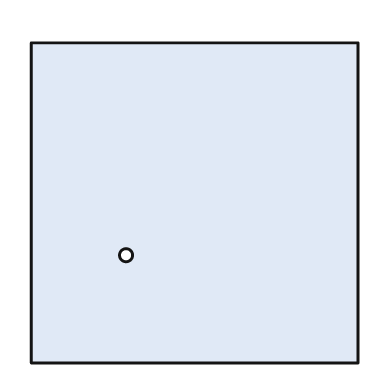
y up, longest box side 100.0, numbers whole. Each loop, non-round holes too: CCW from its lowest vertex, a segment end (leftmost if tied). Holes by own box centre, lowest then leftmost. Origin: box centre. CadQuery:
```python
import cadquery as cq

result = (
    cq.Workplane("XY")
    .moveTo(-50.0, -49.0)
    .lineTo(50.0, -49.0)
    .lineTo(50.0, 49.0)
    .lineTo(-50.0, 49.0)
    .close()
    .moveTo(-21.0, -16.0)
    .circle(2.0)
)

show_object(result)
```